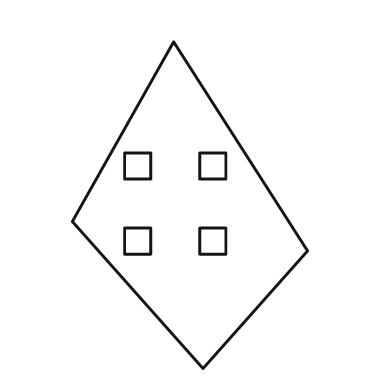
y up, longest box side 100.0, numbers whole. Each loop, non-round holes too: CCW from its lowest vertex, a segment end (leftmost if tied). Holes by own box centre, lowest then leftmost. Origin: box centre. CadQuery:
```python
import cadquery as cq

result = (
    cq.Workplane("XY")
    .moveTo(4.0, -50.0)
    .lineTo(36.0, -14.0)
    .lineTo(-5.0, 50.0)
    .lineTo(-36.0, -5.0)
    .close()
    .moveTo(-20.0, -15.0)
    .lineTo(-12.0, -15.0)
    .lineTo(-12.0, -7.0)
    .lineTo(-20.0, -7.0)
    .close()
    .moveTo(3.0, -15.0)
    .lineTo(11.0, -15.0)
    .lineTo(11.0, -7.0)
    .lineTo(3.0, -7.0)
    .close()
    .moveTo(-20.0, 8.0)
    .lineTo(-12.0, 8.0)
    .lineTo(-12.0, 16.0)
    .lineTo(-20.0, 16.0)
    .close()
    .moveTo(3.0, 8.0)
    .lineTo(11.0, 8.0)
    .lineTo(11.0, 16.0)
    .lineTo(3.0, 16.0)
    .close()
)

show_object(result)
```